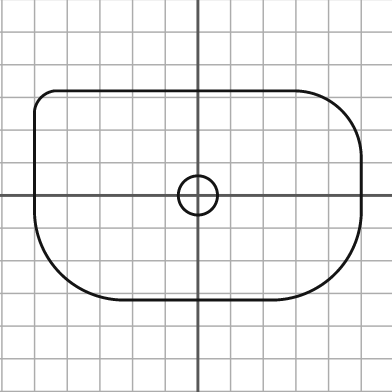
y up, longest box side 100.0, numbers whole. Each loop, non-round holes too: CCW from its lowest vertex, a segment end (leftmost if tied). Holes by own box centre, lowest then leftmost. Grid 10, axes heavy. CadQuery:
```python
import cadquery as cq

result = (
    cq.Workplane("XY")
    .moveTo(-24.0, -32.0)
    .lineTo(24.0, -32.0)
    .threePointArc((42.0, -24.0), (50.0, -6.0))
    .lineTo(50.0, 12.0)
    .threePointArc((44.0, 26.0), (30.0, 32.0))
    .lineTo(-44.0, 32.0)
    .threePointArc((-48.0, 30.0), (-50.0, 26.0))
    .lineTo(-50.0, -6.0)
    .threePointArc((-42.0, -24.0), (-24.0, -32.0))
    .close()
    .moveTo(0.0, 0.0)
    .circle(6.0)
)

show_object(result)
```